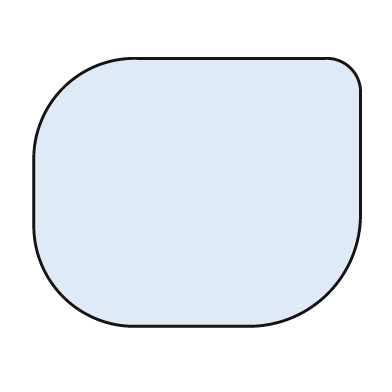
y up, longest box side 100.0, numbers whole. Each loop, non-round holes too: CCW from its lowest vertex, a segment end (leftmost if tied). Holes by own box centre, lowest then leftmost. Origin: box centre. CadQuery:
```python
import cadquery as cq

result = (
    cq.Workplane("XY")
    .moveTo(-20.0, -41.0)
    .lineTo(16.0, -41.0)
    .threePointArc((40.0, -31.0), (50.0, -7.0))
    .lineTo(50.0, 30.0)
    .threePointArc((47.0, 38.0), (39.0, 41.0))
    .lineTo(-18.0, 41.0)
    .threePointArc((-41.0, 32.0), (-50.0, 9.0))
    .lineTo(-50.0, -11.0)
    .threePointArc((-41.0, -32.0), (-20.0, -41.0))
    .close()
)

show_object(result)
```